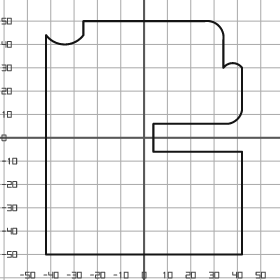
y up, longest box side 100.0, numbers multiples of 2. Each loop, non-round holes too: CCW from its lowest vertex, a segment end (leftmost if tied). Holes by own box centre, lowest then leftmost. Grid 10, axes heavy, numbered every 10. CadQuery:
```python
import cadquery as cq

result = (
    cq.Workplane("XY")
    .moveTo(-42.0, -50.0)
    .lineTo(42.0, -50.0)
    .lineTo(42.0, -6.0)
    .lineTo(4.0, -6.0)
    .lineTo(4.0, 6.0)
    .lineTo(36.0, 6.0)
    .threePointArc((40.0, 8.0), (42.0, 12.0))
    .lineTo(42.0, 30.0)
    .threePointArc((38.0, 32.0), (34.0, 30.0))
    .lineTo(34.0, 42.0)
    .threePointArc((32.0, 48.0), (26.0, 50.0))
    .lineTo(-26.0, 50.0)
    .lineTo(-26.0, 44.0)
    .threePointArc((-34.0, 40.0), (-42.0, 44.0))
    .close()
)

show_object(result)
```